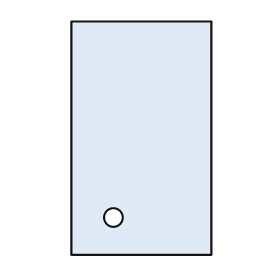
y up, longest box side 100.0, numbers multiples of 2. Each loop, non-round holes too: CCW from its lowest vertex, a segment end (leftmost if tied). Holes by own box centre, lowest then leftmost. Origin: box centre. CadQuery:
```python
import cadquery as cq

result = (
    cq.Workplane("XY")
    .moveTo(-30.0, -50.0)
    .lineTo(30.0, -50.0)
    .lineTo(30.0, 50.0)
    .lineTo(-30.0, 50.0)
    .close()
    .moveTo(-12.0, -34.0)
    .circle(4.0)
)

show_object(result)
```